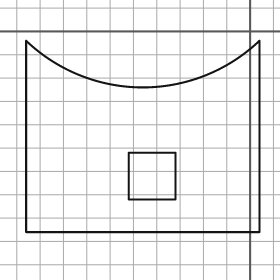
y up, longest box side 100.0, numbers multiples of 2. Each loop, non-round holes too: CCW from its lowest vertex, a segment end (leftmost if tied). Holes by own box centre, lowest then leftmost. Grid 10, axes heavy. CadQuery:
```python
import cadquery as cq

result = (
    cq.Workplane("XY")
    .moveTo(-96.0, -86.0)
    .lineTo(4.0, -86.0)
    .lineTo(4.0, -4.0)
    .threePointArc((-46.0, -24.0), (-96.0, -4.0))
    .close()
    .moveTo(-52.0, -72.0)
    .lineTo(-32.0, -72.0)
    .lineTo(-32.0, -52.0)
    .lineTo(-52.0, -52.0)
    .close()
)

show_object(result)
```